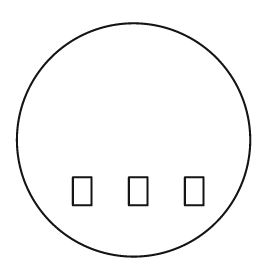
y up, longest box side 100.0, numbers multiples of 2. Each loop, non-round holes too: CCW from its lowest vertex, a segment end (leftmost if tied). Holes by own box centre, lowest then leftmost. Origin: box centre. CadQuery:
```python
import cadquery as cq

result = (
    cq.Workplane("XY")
    .moveTo(0.0, 0.0)
    .circle(50.0)
    .moveTo(-26.0, -28.0)
    .lineTo(-18.0, -28.0)
    .lineTo(-18.0, -16.0)
    .lineTo(-26.0, -16.0)
    .close()
    .moveTo(-2.0, -28.0)
    .lineTo(6.0, -28.0)
    .lineTo(6.0, -16.0)
    .lineTo(-2.0, -16.0)
    .close()
    .moveTo(22.0, -28.0)
    .lineTo(30.0, -28.0)
    .lineTo(30.0, -16.0)
    .lineTo(22.0, -16.0)
    .close()
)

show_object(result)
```